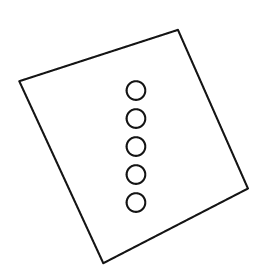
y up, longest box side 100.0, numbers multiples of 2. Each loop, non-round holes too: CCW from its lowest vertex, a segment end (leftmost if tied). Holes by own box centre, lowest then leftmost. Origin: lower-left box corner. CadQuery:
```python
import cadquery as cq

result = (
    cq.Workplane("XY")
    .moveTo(36.0, 0.0)
    .lineTo(98.0, 32.0)
    .lineTo(68.0, 100.0)
    .lineTo(0.0, 78.0)
    .close()
    .moveTo(50.0, 26.0)
    .circle(4.0)
    .moveTo(50.0, 38.0)
    .circle(4.0)
    .moveTo(50.0, 50.0)
    .circle(4.0)
    .moveTo(50.0, 62.0)
    .circle(4.0)
    .moveTo(50.0, 74.0)
    .circle(4.0)
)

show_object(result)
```